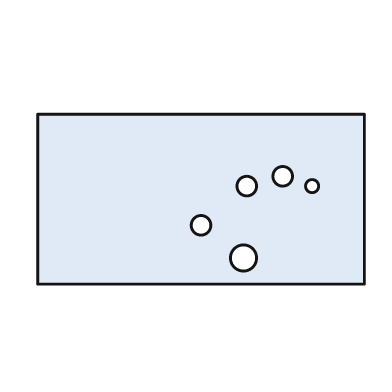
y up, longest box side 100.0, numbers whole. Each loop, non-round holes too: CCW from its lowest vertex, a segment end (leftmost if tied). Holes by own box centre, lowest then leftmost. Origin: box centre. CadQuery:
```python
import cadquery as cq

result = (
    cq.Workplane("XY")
    .moveTo(-50.0, -26.0)
    .lineTo(50.0, -26.0)
    .lineTo(50.0, 26.0)
    .lineTo(-50.0, 26.0)
    .close()
    .moveTo(13.0, -18.0)
    .circle(4.0)
    .moveTo(0.0, -8.0)
    .circle(3.0)
    .moveTo(14.0, 4.0)
    .circle(3.0)
    .moveTo(34.0, 4.0)
    .circle(2.0)
    .moveTo(25.0, 7.0)
    .circle(3.0)
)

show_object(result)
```